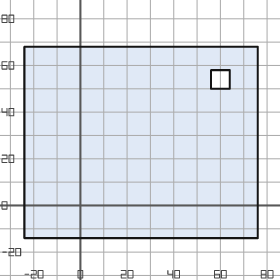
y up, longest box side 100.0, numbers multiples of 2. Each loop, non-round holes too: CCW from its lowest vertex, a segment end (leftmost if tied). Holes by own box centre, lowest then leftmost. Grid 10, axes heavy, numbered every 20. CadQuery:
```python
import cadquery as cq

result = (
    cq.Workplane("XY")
    .moveTo(-24.0, -14.0)
    .lineTo(76.0, -14.0)
    .lineTo(76.0, 68.0)
    .lineTo(-24.0, 68.0)
    .close()
    .moveTo(56.0, 50.0)
    .lineTo(64.0, 50.0)
    .lineTo(64.0, 58.0)
    .lineTo(56.0, 58.0)
    .close()
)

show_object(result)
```